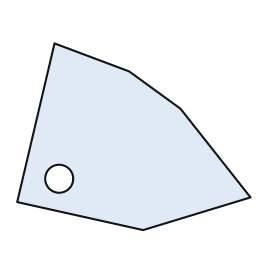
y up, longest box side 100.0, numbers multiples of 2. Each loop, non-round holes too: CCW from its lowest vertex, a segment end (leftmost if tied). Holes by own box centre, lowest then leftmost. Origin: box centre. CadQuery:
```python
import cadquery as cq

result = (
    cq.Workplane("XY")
    .moveTo(4.0, -40.0)
    .lineTo(50.0, -26.0)
    .lineTo(20.0, 12.0)
    .lineTo(-2.0, 28.0)
    .lineTo(-34.0, 40.0)
    .lineTo(-50.0, -28.0)
    .close()
    .moveTo(-32.0, -18.0)
    .circle(6.0)
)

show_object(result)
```